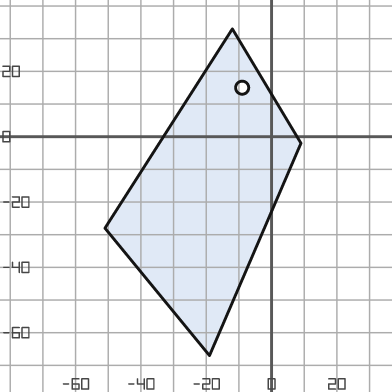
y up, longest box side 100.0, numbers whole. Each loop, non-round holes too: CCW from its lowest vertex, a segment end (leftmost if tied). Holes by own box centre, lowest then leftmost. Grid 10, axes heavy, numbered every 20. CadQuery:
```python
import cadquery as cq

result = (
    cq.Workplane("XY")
    .moveTo(-19.0, -67.0)
    .lineTo(9.0, -2.0)
    .lineTo(-12.0, 33.0)
    .lineTo(-51.0, -28.0)
    .close()
    .moveTo(-9.0, 15.0)
    .circle(2.0)
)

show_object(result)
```